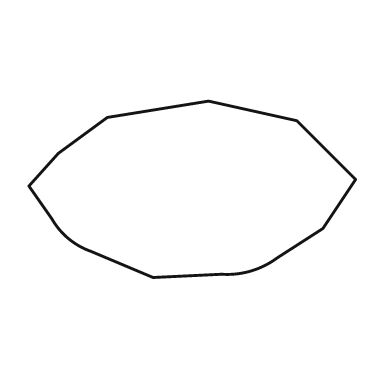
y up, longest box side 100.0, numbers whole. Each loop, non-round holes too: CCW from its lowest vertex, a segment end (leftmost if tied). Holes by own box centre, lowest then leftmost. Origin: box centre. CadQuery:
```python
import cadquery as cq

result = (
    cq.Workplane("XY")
    .moveTo(-12.0, -27.0)
    .lineTo(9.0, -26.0)
    .threePointArc((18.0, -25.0), (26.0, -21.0))
    .lineTo(40.0, -12.0)
    .lineTo(50.0, 3.0)
    .lineTo(32.0, 21.0)
    .lineTo(5.0, 27.0)
    .lineTo(-26.0, 22.0)
    .lineTo(-41.0, 11.0)
    .lineTo(-50.0, 1.0)
    .lineTo(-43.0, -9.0)
    .threePointArc((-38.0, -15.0), (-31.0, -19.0))
    .close()
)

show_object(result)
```